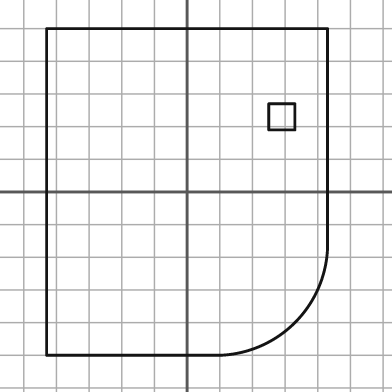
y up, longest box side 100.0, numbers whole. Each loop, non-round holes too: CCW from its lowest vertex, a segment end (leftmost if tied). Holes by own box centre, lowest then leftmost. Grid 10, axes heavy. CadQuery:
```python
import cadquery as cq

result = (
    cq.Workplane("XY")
    .moveTo(-43.0, -50.0)
    .lineTo(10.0, -50.0)
    .threePointArc((33.0, -40.0), (43.0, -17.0))
    .lineTo(43.0, 50.0)
    .lineTo(-43.0, 50.0)
    .close()
    .moveTo(25.0, 19.0)
    .lineTo(33.0, 19.0)
    .lineTo(33.0, 27.0)
    .lineTo(25.0, 27.0)
    .close()
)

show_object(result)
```